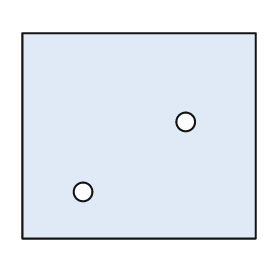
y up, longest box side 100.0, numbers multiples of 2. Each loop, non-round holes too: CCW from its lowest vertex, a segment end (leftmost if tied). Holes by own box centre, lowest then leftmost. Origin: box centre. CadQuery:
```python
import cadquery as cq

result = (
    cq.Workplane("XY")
    .moveTo(-50.0, -44.0)
    .lineTo(50.0, -44.0)
    .lineTo(50.0, 44.0)
    .lineTo(-50.0, 44.0)
    .close()
    .moveTo(-24.0, -24.0)
    .circle(4.0)
    .moveTo(20.0, 6.0)
    .circle(4.0)
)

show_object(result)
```